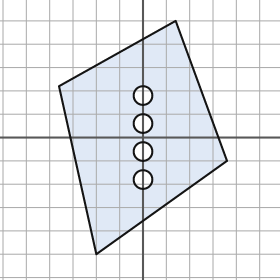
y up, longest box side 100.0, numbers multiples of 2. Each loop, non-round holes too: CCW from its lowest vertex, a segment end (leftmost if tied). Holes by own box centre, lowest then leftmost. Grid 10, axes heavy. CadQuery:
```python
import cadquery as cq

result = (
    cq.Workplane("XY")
    .moveTo(-20.0, -50.0)
    .lineTo(36.0, -10.0)
    .lineTo(14.0, 50.0)
    .lineTo(-36.0, 22.0)
    .close()
    .moveTo(0.0, -18.0)
    .circle(4.0)
    .moveTo(0.0, -6.0)
    .circle(4.0)
    .moveTo(0.0, 6.0)
    .circle(4.0)
    .moveTo(0.0, 18.0)
    .circle(4.0)
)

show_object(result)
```